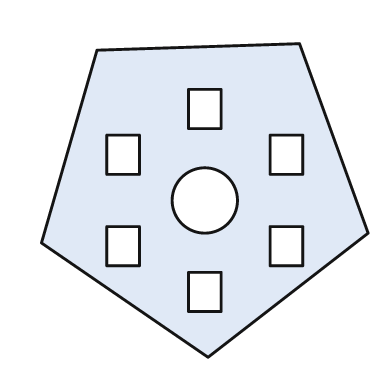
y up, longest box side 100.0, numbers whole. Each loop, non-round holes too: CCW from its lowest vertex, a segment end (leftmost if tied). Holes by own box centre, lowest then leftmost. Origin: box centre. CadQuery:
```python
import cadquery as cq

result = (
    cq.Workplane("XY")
    .moveTo(1.0, -48.0)
    .lineTo(50.0, -10.0)
    .lineTo(29.0, 48.0)
    .lineTo(-33.0, 46.0)
    .lineTo(-50.0, -13.0)
    .close()
    .moveTo(-5.0, -34.0)
    .lineTo(5.0, -34.0)
    .lineTo(5.0, -22.0)
    .lineTo(-5.0, -22.0)
    .close()
    .moveTo(-30.0, -20.0)
    .lineTo(-20.0, -20.0)
    .lineTo(-20.0, -8.0)
    .lineTo(-30.0, -8.0)
    .close()
    .moveTo(20.0, -20.0)
    .lineTo(30.0, -20.0)
    .lineTo(30.0, -8.0)
    .lineTo(20.0, -8.0)
    .close()
    .moveTo(0.0, 0.0)
    .circle(10.0)
    .moveTo(-30.0, 8.0)
    .lineTo(-20.0, 8.0)
    .lineTo(-20.0, 20.0)
    .lineTo(-30.0, 20.0)
    .close()
    .moveTo(20.0, 8.0)
    .lineTo(30.0, 8.0)
    .lineTo(30.0, 20.0)
    .lineTo(20.0, 20.0)
    .close()
    .moveTo(-5.0, 22.0)
    .lineTo(5.0, 22.0)
    .lineTo(5.0, 34.0)
    .lineTo(-5.0, 34.0)
    .close()
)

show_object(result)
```